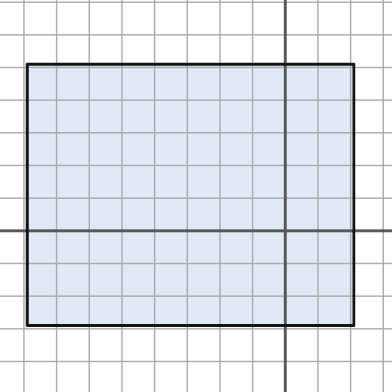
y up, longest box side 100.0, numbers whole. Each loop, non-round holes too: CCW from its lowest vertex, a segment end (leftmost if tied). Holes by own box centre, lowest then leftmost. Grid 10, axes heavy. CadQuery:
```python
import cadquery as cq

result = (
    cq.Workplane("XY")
    .moveTo(-79.0, -29.0)
    .lineTo(21.0, -29.0)
    .lineTo(21.0, 51.0)
    .lineTo(-79.0, 51.0)
    .close()
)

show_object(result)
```